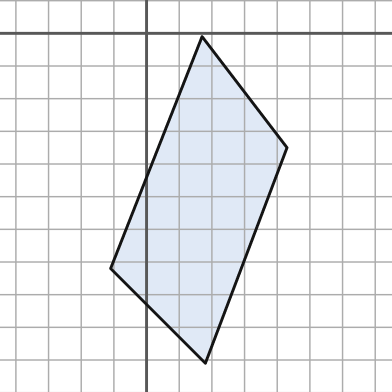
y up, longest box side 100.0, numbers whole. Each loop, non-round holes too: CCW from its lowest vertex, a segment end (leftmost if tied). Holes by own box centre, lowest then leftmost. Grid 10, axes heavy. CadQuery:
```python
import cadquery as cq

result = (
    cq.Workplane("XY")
    .moveTo(18.0, -101.0)
    .lineTo(43.0, -35.0)
    .lineTo(17.0, -1.0)
    .lineTo(-11.0, -72.0)
    .close()
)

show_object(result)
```